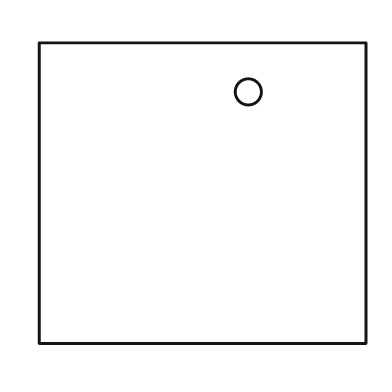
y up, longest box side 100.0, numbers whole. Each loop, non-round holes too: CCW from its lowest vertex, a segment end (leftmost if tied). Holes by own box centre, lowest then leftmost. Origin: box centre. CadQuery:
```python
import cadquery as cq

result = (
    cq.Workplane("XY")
    .moveTo(-50.0, -46.0)
    .lineTo(50.0, -46.0)
    .lineTo(50.0, 46.0)
    .lineTo(-50.0, 46.0)
    .close()
    .moveTo(14.0, 31.0)
    .circle(4.0)
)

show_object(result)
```